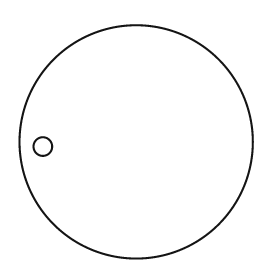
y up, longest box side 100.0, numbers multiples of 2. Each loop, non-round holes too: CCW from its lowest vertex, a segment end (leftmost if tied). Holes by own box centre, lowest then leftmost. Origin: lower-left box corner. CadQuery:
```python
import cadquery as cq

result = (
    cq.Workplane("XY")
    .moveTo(50.0, 50.0)
    .circle(50.0)
    .moveTo(10.0, 48.0)
    .circle(4.0)
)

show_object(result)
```